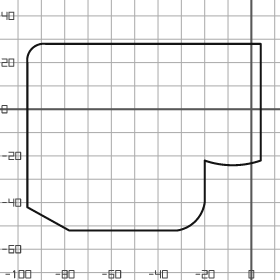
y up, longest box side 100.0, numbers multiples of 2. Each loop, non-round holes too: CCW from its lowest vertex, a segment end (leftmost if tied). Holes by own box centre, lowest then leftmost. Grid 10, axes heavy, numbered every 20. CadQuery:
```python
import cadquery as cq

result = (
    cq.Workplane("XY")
    .moveTo(-78.0, -52.0)
    .lineTo(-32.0, -52.0)
    .threePointArc((-24.0, -48.0), (-20.0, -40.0))
    .lineTo(-20.0, -22.0)
    .threePointArc((-8.0, -24.0), (4.0, -22.0))
    .lineTo(4.0, 28.0)
    .lineTo(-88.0, 28.0)
    .threePointArc((-94.0, 26.0), (-96.0, 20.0))
    .lineTo(-96.0, -42.0)
    .close()
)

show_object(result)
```